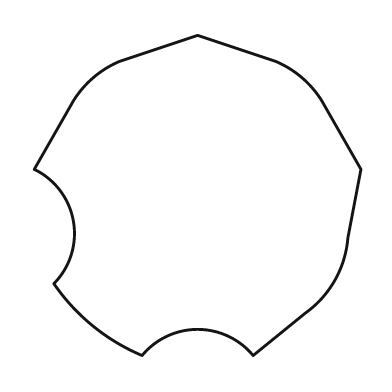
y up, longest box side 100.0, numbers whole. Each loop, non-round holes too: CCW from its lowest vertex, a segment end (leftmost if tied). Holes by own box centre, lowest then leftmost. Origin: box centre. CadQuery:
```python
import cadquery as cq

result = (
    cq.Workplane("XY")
    .moveTo(-17.0, -49.0)
    .threePointArc((0.0, -41.0), (17.0, -49.0))
    .lineTo(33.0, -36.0)
    .threePointArc((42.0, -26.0), (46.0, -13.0))
    .lineTo(50.0, 8.0)
    .lineTo(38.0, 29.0)
    .threePointArc((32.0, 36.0), (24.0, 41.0))
    .lineTo(0.0, 49.0)
    .lineTo(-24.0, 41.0)
    .threePointArc((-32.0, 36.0), (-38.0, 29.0))
    .lineTo(-50.0, 8.0)
    .threePointArc((-38.0, -8.0), (-44.0, -27.0))
    .threePointArc((-32.0, -40.0), (-17.0, -49.0))
    .close()
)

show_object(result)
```